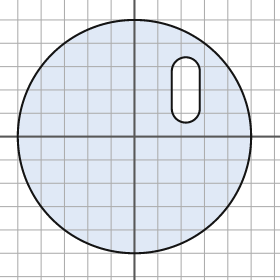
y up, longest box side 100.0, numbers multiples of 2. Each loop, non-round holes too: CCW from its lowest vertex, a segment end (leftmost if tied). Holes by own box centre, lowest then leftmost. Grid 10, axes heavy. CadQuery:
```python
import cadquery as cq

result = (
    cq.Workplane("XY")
    .moveTo(0.0, 0.0)
    .circle(50.0)
    .moveTo(16.0, 12.0)
    .threePointArc((22.0, 6.0), (28.0, 12.0))
    .lineTo(28.0, 28.0)
    .threePointArc((22.0, 34.0), (16.0, 28.0))
    .close()
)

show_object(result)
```